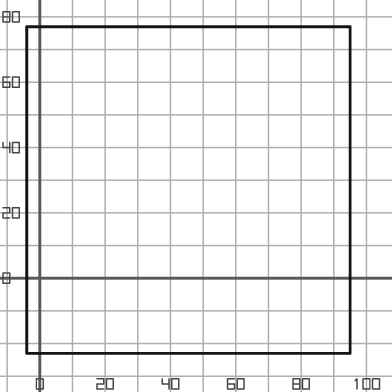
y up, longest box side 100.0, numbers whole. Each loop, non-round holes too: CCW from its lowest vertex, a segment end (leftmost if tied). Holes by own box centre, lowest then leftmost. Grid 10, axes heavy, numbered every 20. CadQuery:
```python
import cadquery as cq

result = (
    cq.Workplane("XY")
    .moveTo(-4.0, -23.0)
    .lineTo(95.0, -23.0)
    .lineTo(95.0, 77.0)
    .lineTo(-4.0, 77.0)
    .close()
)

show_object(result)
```